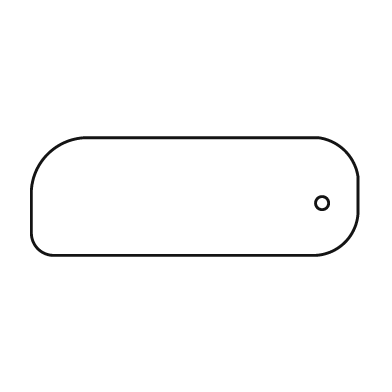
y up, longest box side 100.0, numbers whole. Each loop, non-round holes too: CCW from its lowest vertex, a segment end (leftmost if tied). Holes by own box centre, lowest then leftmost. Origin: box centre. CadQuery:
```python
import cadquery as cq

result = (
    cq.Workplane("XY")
    .moveTo(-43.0, -18.0)
    .lineTo(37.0, -18.0)
    .threePointArc((46.0, -14.0), (50.0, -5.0))
    .lineTo(50.0, 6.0)
    .threePointArc((46.0, 14.0), (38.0, 18.0))
    .lineTo(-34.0, 18.0)
    .threePointArc((-45.0, 13.0), (-50.0, 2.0))
    .lineTo(-50.0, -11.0)
    .threePointArc((-48.0, -16.0), (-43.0, -18.0))
    .close()
    .moveTo(39.0, -2.0)
    .circle(2.0)
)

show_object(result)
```